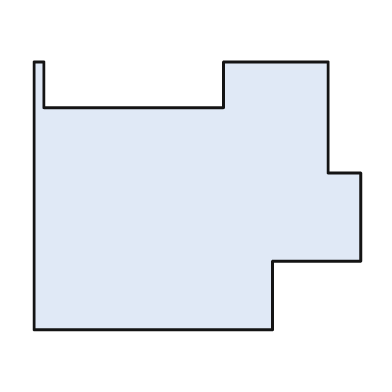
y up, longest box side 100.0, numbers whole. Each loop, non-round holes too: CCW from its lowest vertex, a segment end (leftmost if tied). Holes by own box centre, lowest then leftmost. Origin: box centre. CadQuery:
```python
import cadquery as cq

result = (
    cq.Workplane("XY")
    .moveTo(-50.0, -41.0)
    .lineTo(23.0, -41.0)
    .lineTo(23.0, -20.0)
    .lineTo(50.0, -20.0)
    .lineTo(50.0, 7.0)
    .lineTo(40.0, 7.0)
    .lineTo(40.0, 41.0)
    .lineTo(8.0, 41.0)
    .lineTo(8.0, 27.0)
    .lineTo(-47.0, 27.0)
    .lineTo(-47.0, 41.0)
    .lineTo(-50.0, 41.0)
    .close()
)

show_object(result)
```